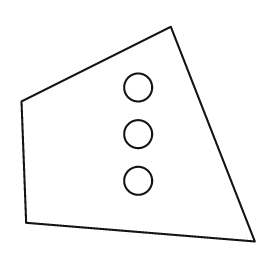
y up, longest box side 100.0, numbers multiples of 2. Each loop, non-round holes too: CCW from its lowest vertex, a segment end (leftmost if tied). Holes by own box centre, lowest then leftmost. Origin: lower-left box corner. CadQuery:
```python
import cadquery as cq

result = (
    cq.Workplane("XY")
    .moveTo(100.0, 0.0)
    .lineTo(64.0, 92.0)
    .lineTo(0.0, 60.0)
    .lineTo(2.0, 8.0)
    .close()
    .moveTo(50.0, 26.0)
    .circle(6.0)
    .moveTo(50.0, 46.0)
    .circle(6.0)
    .moveTo(50.0, 66.0)
    .circle(6.0)
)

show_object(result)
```